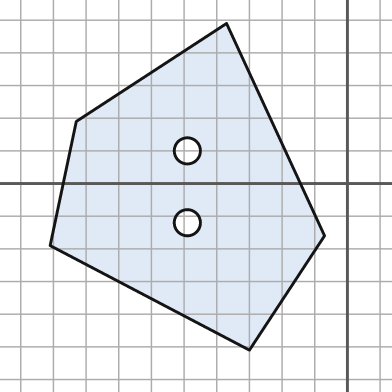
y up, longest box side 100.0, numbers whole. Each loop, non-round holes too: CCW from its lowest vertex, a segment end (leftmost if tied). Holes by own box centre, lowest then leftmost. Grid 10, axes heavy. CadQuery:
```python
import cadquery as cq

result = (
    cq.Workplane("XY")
    .moveTo(-30.0, -51.0)
    .lineTo(-7.0, -16.0)
    .lineTo(-37.0, 49.0)
    .lineTo(-83.0, 19.0)
    .lineTo(-91.0, -19.0)
    .close()
    .moveTo(-49.0, -12.0)
    .circle(4.0)
    .moveTo(-49.0, 10.0)
    .circle(4.0)
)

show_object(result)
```